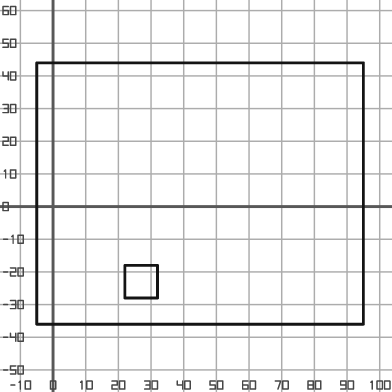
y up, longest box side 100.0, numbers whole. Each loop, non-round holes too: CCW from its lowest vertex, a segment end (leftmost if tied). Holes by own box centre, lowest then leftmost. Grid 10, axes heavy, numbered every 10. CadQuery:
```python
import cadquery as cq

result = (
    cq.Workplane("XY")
    .moveTo(-5.0, -36.0)
    .lineTo(95.0, -36.0)
    .lineTo(95.0, 44.0)
    .lineTo(-5.0, 44.0)
    .close()
    .moveTo(22.0, -28.0)
    .lineTo(32.0, -28.0)
    .lineTo(32.0, -18.0)
    .lineTo(22.0, -18.0)
    .close()
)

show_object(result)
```